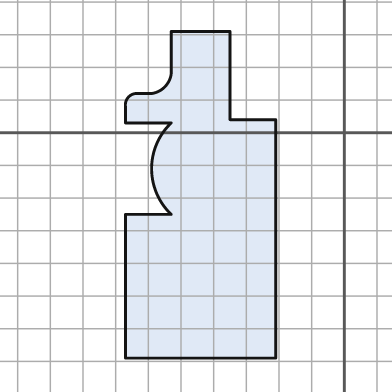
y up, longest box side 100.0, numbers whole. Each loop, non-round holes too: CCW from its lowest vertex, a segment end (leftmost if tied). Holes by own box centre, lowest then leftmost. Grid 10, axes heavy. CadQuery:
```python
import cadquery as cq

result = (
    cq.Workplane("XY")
    .moveTo(-67.0, -69.0)
    .lineTo(-21.0, -69.0)
    .lineTo(-21.0, 4.0)
    .lineTo(-35.0, 4.0)
    .lineTo(-35.0, 31.0)
    .lineTo(-53.0, 31.0)
    .lineTo(-53.0, 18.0)
    .threePointArc((-55.0, 14.0), (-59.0, 12.0))
    .lineTo(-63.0, 12.0)
    .threePointArc((-66.0, 11.0), (-67.0, 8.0))
    .lineTo(-67.0, 3.0)
    .lineTo(-53.0, 3.0)
    .threePointArc((-59.0, -11.0), (-53.0, -25.0))
    .lineTo(-67.0, -25.0)
    .close()
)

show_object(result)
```